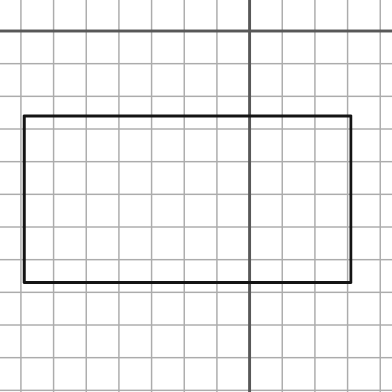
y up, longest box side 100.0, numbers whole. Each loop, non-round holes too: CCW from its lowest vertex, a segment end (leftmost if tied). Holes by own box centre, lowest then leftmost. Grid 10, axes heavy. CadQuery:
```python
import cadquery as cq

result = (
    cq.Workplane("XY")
    .moveTo(-69.0, -77.0)
    .lineTo(31.0, -77.0)
    .lineTo(31.0, -26.0)
    .lineTo(-69.0, -26.0)
    .close()
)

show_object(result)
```